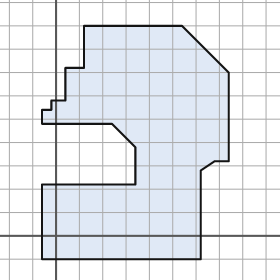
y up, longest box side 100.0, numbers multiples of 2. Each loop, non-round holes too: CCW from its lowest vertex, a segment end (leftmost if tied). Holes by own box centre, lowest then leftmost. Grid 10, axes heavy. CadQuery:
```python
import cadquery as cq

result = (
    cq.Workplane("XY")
    .moveTo(-6.0, -10.0)
    .lineTo(62.0, -10.0)
    .lineTo(62.0, 28.0)
    .lineTo(68.0, 32.0)
    .lineTo(74.0, 32.0)
    .lineTo(74.0, 70.0)
    .lineTo(54.0, 90.0)
    .lineTo(12.0, 90.0)
    .lineTo(12.0, 72.0)
    .lineTo(4.0, 72.0)
    .lineTo(4.0, 58.0)
    .lineTo(-2.0, 58.0)
    .lineTo(-2.0, 54.0)
    .lineTo(-6.0, 54.0)
    .lineTo(-6.0, 48.0)
    .lineTo(24.0, 48.0)
    .lineTo(34.0, 38.0)
    .lineTo(34.0, 22.0)
    .lineTo(-6.0, 22.0)
    .close()
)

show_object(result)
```